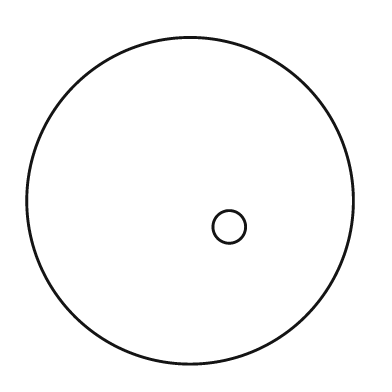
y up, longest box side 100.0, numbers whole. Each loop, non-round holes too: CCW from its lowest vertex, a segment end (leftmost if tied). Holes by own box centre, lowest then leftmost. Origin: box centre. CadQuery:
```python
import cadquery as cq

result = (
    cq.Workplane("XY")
    .moveTo(0.0, 0.0)
    .circle(50.0)
    .moveTo(12.0, -8.0)
    .circle(5.0)
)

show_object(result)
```